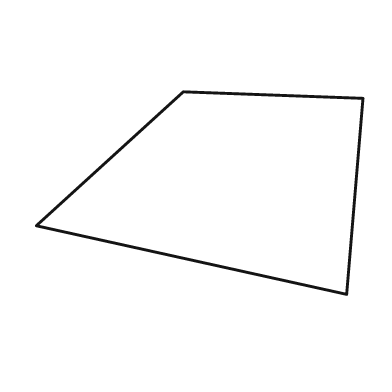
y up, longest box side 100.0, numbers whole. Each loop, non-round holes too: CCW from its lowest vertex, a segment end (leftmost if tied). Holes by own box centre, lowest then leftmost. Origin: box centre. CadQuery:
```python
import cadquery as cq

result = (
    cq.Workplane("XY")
    .moveTo(45.0, -31.0)
    .lineTo(50.0, 29.0)
    .lineTo(-5.0, 31.0)
    .lineTo(-50.0, -10.0)
    .close()
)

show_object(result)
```